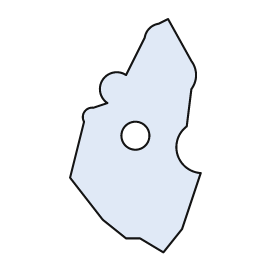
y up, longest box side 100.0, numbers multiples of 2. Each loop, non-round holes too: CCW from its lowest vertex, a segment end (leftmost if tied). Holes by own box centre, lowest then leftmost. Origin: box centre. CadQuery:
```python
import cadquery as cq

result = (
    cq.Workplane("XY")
    .moveTo(12.0, -50.0)
    .lineTo(20.0, -40.0)
    .lineTo(28.0, -16.0)
    .threePointArc((18.0, -8.0), (22.0, 4.0))
    .lineTo(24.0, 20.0)
    .threePointArc((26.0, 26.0), (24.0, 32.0))
    .lineTo(14.0, 50.0)
    .lineTo(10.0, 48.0)
    .threePointArc((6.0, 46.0), (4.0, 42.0))
    .lineTo(-4.0, 26.0)
    .threePointArc((-14.0, 24.0), (-12.0, 14.0))
    .lineTo(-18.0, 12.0)
    .threePointArc((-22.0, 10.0), (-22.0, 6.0))
    .lineTo(-28.0, -18.0)
    .lineTo(-14.0, -36.0)
    .lineTo(-4.0, -44.0)
    .lineTo(2.0, -44.0)
    .close()
    .moveTo(0.0, 0.0)
    .circle(6.0)
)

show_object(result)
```